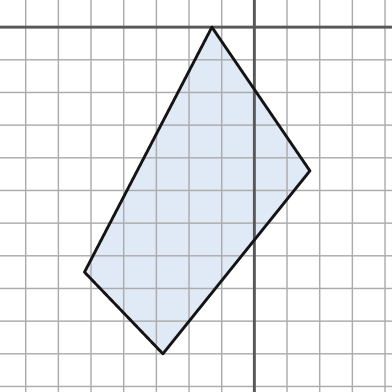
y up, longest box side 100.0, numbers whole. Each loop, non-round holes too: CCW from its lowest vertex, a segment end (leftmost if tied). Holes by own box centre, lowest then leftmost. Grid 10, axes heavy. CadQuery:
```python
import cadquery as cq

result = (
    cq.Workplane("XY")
    .moveTo(-28.0, -100.0)
    .lineTo(17.0, -44.0)
    .lineTo(-13.0, 0.0)
    .lineTo(-52.0, -75.0)
    .close()
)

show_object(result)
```